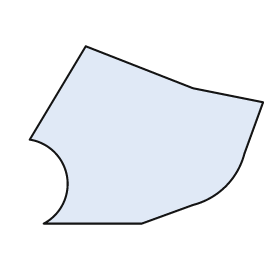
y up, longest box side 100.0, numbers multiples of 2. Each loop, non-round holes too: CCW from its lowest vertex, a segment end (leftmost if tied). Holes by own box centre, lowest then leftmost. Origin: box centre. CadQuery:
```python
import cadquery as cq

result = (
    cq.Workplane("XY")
    .moveTo(-44.0, -38.0)
    .lineTo(-2.0, -38.0)
    .lineTo(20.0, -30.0)
    .threePointArc((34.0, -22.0), (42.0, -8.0))
    .lineTo(50.0, 14.0)
    .lineTo(20.0, 20.0)
    .lineTo(-26.0, 38.0)
    .lineTo(-50.0, -2.0)
    .threePointArc((-34.0, -18.0), (-44.0, -38.0))
    .close()
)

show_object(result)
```